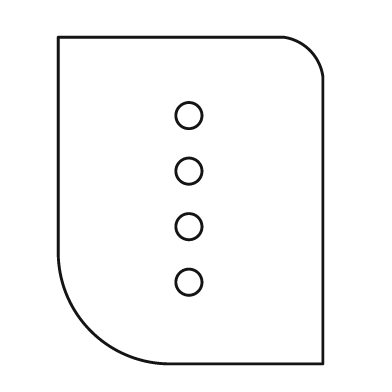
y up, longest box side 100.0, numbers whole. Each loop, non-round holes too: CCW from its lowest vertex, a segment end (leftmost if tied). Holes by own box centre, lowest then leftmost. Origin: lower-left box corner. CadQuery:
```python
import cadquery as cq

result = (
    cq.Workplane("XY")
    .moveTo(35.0, 0.0)
    .lineTo(81.0, 0.0)
    .lineTo(81.0, 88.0)
    .threePointArc((77.0, 96.0), (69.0, 100.0))
    .lineTo(0.0, 100.0)
    .lineTo(0.0, 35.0)
    .threePointArc((10.0, 10.0), (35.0, 0.0))
    .close()
    .moveTo(40.0, 25.0)
    .circle(4.0)
    .moveTo(40.0, 42.0)
    .circle(4.0)
    .moveTo(40.0, 59.0)
    .circle(4.0)
    .moveTo(40.0, 76.0)
    .circle(4.0)
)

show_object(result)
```